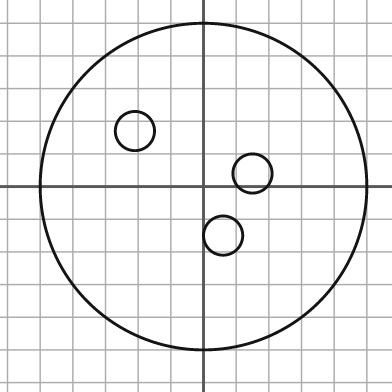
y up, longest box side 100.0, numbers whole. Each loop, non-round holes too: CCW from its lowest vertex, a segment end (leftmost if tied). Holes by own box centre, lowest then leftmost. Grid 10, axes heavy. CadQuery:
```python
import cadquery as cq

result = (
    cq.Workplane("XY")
    .moveTo(0.0, 0.0)
    .circle(50.0)
    .moveTo(6.0, -15.0)
    .circle(6.0)
    .moveTo(15.0, 4.0)
    .circle(6.0)
    .moveTo(-21.0, 17.0)
    .circle(6.0)
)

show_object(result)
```